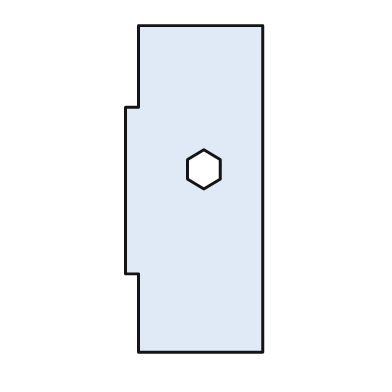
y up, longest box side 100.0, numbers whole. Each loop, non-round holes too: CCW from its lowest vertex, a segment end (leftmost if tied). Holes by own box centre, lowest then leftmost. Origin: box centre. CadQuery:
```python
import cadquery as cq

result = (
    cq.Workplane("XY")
    .moveTo(-17.0, -50.0)
    .lineTo(21.0, -50.0)
    .lineTo(21.0, 50.0)
    .lineTo(-17.0, 50.0)
    .lineTo(-17.0, 25.0)
    .lineTo(-21.0, 25.0)
    .lineTo(-21.0, -26.0)
    .lineTo(-17.0, -26.0)
    .close()
    .moveTo(3.0, 0.0)
    .lineTo(8.0, 3.0)
    .lineTo(8.0, 9.0)
    .lineTo(3.0, 12.0)
    .lineTo(-2.0, 9.0)
    .lineTo(-2.0, 3.0)
    .close()
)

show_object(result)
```